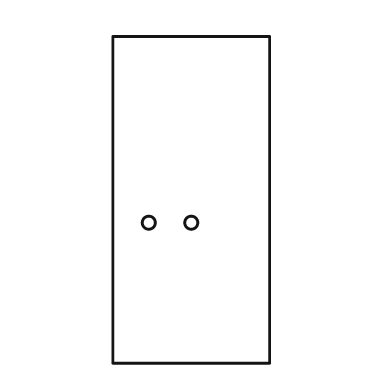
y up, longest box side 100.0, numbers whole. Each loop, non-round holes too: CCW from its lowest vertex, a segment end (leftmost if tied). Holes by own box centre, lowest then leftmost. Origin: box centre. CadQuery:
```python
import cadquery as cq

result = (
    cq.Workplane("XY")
    .moveTo(-24.0, -50.0)
    .lineTo(24.0, -50.0)
    .lineTo(24.0, 50.0)
    .lineTo(-24.0, 50.0)
    .close()
    .moveTo(-13.0, -7.0)
    .circle(2.0)
    .moveTo(0.0, -7.0)
    .circle(2.0)
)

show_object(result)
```